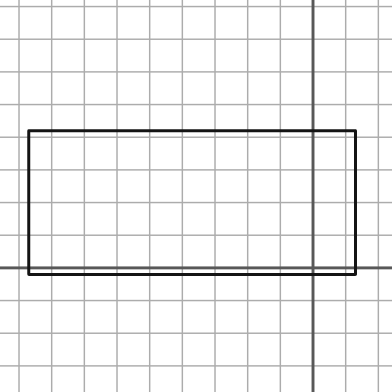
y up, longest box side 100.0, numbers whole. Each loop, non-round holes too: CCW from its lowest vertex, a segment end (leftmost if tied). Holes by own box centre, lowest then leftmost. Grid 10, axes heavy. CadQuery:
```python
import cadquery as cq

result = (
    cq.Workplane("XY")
    .moveTo(-87.0, -2.0)
    .lineTo(13.0, -2.0)
    .lineTo(13.0, 42.0)
    .lineTo(-87.0, 42.0)
    .close()
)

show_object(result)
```